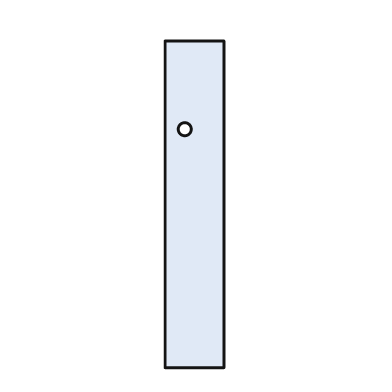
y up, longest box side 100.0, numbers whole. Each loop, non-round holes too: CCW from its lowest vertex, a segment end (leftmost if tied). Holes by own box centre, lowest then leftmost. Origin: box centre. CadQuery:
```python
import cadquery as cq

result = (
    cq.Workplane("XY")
    .moveTo(-9.0, -50.0)
    .lineTo(9.0, -50.0)
    .lineTo(9.0, 50.0)
    .lineTo(-9.0, 50.0)
    .close()
    .moveTo(-3.0, 23.0)
    .circle(2.0)
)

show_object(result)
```